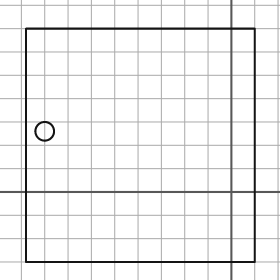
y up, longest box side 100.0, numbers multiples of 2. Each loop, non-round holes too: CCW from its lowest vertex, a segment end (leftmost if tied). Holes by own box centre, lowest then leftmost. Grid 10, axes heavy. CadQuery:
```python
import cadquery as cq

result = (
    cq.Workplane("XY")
    .moveTo(-88.0, -30.0)
    .lineTo(10.0, -30.0)
    .lineTo(10.0, 70.0)
    .lineTo(-88.0, 70.0)
    .close()
    .moveTo(-80.0, 26.0)
    .circle(4.0)
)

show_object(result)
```